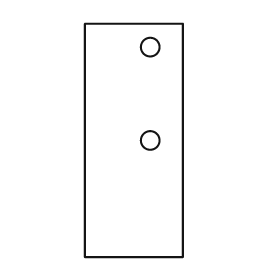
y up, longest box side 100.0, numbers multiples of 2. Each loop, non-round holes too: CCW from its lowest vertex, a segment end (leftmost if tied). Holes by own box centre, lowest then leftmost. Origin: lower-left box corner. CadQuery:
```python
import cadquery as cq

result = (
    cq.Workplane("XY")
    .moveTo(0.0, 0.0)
    .lineTo(42.0, 0.0)
    .lineTo(42.0, 100.0)
    .lineTo(0.0, 100.0)
    .close()
    .moveTo(28.0, 50.0)
    .circle(4.0)
    .moveTo(28.0, 90.0)
    .circle(4.0)
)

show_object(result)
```